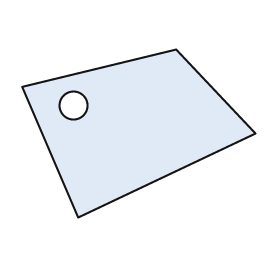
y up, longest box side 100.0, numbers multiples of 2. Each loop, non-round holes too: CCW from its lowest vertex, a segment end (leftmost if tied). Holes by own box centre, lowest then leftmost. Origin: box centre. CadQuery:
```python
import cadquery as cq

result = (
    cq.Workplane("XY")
    .moveTo(-26.0, -36.0)
    .lineTo(50.0, 0.0)
    .lineTo(16.0, 36.0)
    .lineTo(-50.0, 20.0)
    .close()
    .moveTo(-28.0, 12.0)
    .circle(6.0)
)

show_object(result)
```